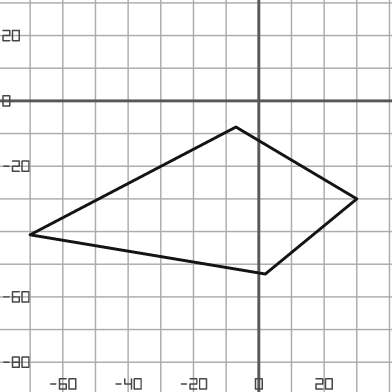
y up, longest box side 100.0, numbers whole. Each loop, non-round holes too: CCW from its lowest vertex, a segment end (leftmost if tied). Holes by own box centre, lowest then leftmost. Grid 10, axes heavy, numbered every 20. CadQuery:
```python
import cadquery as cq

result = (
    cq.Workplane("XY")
    .moveTo(2.0, -53.0)
    .lineTo(30.0, -30.0)
    .lineTo(-7.0, -8.0)
    .lineTo(-70.0, -41.0)
    .close()
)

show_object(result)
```